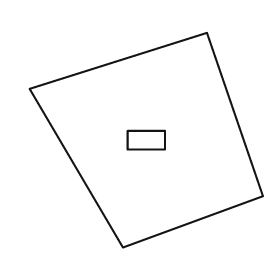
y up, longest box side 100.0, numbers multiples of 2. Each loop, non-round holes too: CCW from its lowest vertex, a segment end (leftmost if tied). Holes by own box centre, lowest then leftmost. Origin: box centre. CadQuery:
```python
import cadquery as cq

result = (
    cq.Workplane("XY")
    .moveTo(-10.0, -46.0)
    .lineTo(50.0, -24.0)
    .lineTo(26.0, 46.0)
    .lineTo(-50.0, 22.0)
    .close()
    .moveTo(-8.0, -4.0)
    .lineTo(8.0, -4.0)
    .lineTo(8.0, 4.0)
    .lineTo(-8.0, 4.0)
    .close()
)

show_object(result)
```